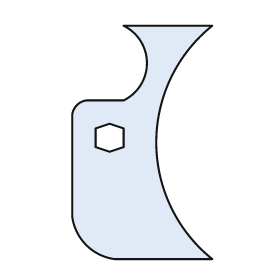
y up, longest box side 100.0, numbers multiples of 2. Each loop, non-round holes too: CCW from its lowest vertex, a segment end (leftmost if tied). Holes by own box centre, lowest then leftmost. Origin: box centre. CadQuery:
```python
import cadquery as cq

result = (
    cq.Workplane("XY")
    .moveTo(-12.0, -50.0)
    .lineTo(30.0, -50.0)
    .threePointArc((6.0, 0.0), (30.0, 50.0))
    .lineTo(-8.0, 50.0)
    .threePointArc((2.0, 34.0), (-8.0, 18.0))
    .lineTo(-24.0, 18.0)
    .threePointArc((-28.0, 16.0), (-30.0, 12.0))
    .lineTo(-30.0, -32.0)
    .threePointArc((-24.0, -44.0), (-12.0, -50.0))
    .close()
    .moveTo(-14.0, -4.0)
    .lineTo(-8.0, -2.0)
    .lineTo(-8.0, 6.0)
    .lineTo(-14.0, 8.0)
    .lineTo(-20.0, 6.0)
    .lineTo(-20.0, -2.0)
    .close()
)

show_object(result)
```